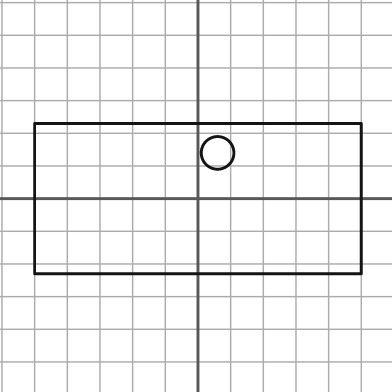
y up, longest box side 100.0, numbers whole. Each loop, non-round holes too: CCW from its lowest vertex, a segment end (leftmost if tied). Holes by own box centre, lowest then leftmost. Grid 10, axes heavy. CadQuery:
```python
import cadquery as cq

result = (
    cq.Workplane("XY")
    .moveTo(-50.0, -23.0)
    .lineTo(50.0, -23.0)
    .lineTo(50.0, 23.0)
    .lineTo(-50.0, 23.0)
    .close()
    .moveTo(6.0, 14.0)
    .circle(5.0)
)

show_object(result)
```